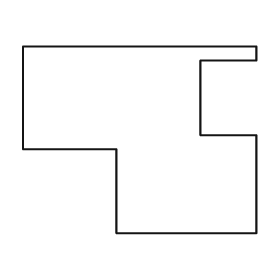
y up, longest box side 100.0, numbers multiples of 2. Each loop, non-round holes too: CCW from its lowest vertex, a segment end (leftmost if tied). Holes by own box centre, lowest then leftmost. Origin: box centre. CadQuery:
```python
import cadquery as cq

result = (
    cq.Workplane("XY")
    .moveTo(-10.0, -40.0)
    .lineTo(50.0, -40.0)
    .lineTo(50.0, 2.0)
    .lineTo(26.0, 2.0)
    .lineTo(26.0, 34.0)
    .lineTo(50.0, 34.0)
    .lineTo(50.0, 40.0)
    .lineTo(-50.0, 40.0)
    .lineTo(-50.0, -4.0)
    .lineTo(-10.0, -4.0)
    .close()
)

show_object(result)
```